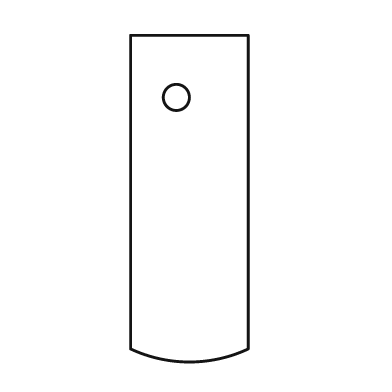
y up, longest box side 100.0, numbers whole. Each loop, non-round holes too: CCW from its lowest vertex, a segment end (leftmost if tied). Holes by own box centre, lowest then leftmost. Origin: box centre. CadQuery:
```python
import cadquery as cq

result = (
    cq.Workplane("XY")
    .moveTo(-18.0, -46.0)
    .threePointArc((0.0, -50.0), (18.0, -46.0))
    .lineTo(18.0, 50.0)
    .lineTo(-18.0, 50.0)
    .close()
    .moveTo(-4.0, 31.0)
    .circle(4.0)
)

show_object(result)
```